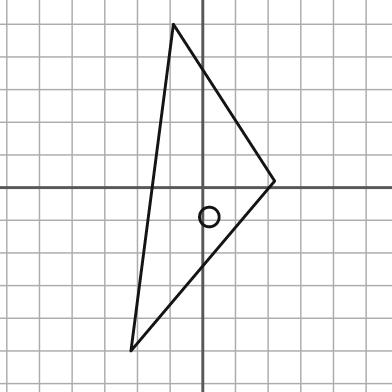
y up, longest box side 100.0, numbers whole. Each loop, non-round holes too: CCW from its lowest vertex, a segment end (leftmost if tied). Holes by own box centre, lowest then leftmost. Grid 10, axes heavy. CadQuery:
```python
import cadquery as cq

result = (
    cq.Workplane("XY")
    .moveTo(-22.0, -50.0)
    .lineTo(22.0, 2.0)
    .lineTo(-9.0, 50.0)
    .close()
    .moveTo(2.0, -9.0)
    .circle(3.0)
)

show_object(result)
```